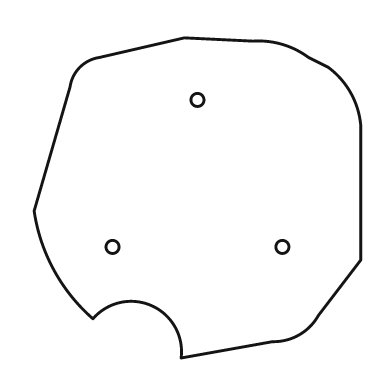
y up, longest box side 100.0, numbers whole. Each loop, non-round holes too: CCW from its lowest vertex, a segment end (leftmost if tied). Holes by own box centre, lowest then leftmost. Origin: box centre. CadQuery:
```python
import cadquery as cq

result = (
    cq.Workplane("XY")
    .moveTo(-5.0, -49.0)
    .lineTo(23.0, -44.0)
    .threePointArc((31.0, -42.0), (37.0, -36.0))
    .lineTo(50.0, -19.0)
    .lineTo(50.0, 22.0)
    .threePointArc((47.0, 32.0), (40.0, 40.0))
    .lineTo(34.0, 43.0)
    .threePointArc((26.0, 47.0), (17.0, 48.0))
    .lineTo(-4.0, 49.0)
    .lineTo(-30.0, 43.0)
    .threePointArc((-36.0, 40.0), (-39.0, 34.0))
    .lineTo(-50.0, -4.0)
    .threePointArc((-44.0, -22.0), (-32.0, -37.0))
    .threePointArc((-14.0, -33.0), (-5.0, -49.0))
    .close()
    .moveTo(-26.0, -15.0)
    .circle(2.0)
    .moveTo(26.0, -15.0)
    .circle(2.0)
    .moveTo(0.0, 30.0)
    .circle(2.0)
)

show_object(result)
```